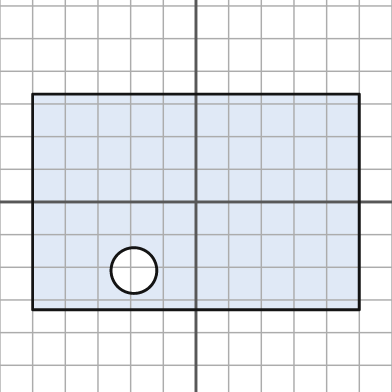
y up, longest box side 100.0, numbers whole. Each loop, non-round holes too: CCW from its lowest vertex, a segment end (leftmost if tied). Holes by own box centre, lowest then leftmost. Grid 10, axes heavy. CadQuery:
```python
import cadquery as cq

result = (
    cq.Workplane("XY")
    .moveTo(-50.0, -33.0)
    .lineTo(50.0, -33.0)
    .lineTo(50.0, 33.0)
    .lineTo(-50.0, 33.0)
    .close()
    .moveTo(-19.0, -21.0)
    .circle(7.0)
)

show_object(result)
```